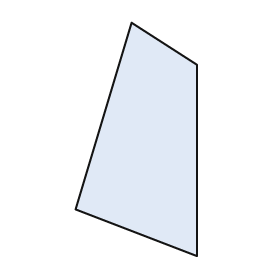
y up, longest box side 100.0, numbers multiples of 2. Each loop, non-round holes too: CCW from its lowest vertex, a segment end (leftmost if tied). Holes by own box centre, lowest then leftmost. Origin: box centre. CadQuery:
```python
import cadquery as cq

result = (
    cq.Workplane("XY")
    .moveTo(26.0, -50.0)
    .lineTo(26.0, 32.0)
    .lineTo(-2.0, 50.0)
    .lineTo(-26.0, -30.0)
    .close()
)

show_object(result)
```